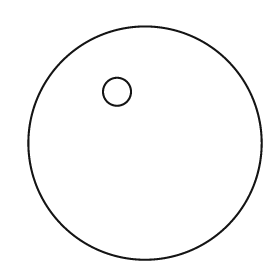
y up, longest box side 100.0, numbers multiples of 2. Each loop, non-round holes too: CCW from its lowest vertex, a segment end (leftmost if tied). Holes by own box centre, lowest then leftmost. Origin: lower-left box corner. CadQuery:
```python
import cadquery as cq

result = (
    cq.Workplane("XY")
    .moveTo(50.0, 50.0)
    .circle(50.0)
    .moveTo(38.0, 72.0)
    .circle(6.0)
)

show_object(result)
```